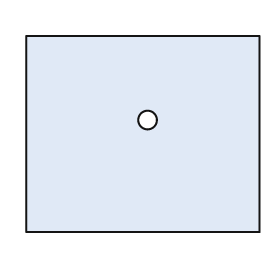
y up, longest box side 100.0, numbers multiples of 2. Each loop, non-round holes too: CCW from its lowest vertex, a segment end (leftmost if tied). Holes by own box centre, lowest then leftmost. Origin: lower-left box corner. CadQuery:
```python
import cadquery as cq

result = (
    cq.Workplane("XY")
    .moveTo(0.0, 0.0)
    .lineTo(100.0, 0.0)
    .lineTo(100.0, 84.0)
    .lineTo(0.0, 84.0)
    .close()
    .moveTo(52.0, 48.0)
    .circle(4.0)
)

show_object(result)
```